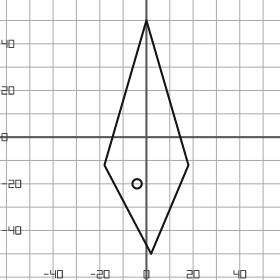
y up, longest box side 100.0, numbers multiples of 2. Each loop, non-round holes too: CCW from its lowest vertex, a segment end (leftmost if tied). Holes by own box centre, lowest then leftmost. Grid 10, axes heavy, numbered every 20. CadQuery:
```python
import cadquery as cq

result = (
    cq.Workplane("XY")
    .moveTo(2.0, -50.0)
    .lineTo(18.0, -12.0)
    .lineTo(0.0, 50.0)
    .lineTo(-18.0, -12.0)
    .close()
    .moveTo(-4.0, -20.0)
    .circle(2.0)
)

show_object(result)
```